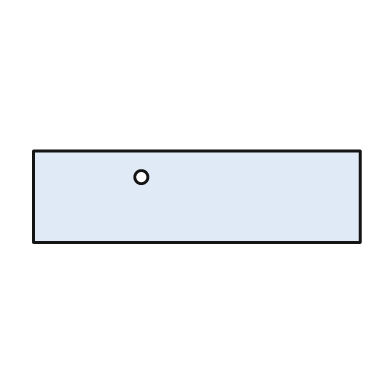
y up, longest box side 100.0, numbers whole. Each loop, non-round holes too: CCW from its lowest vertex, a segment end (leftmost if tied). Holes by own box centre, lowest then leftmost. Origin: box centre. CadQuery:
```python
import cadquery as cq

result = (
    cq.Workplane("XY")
    .moveTo(-50.0, -14.0)
    .lineTo(50.0, -14.0)
    .lineTo(50.0, 14.0)
    .lineTo(-50.0, 14.0)
    .close()
    .moveTo(-17.0, 6.0)
    .circle(2.0)
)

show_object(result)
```